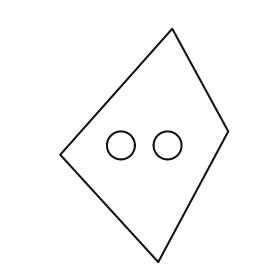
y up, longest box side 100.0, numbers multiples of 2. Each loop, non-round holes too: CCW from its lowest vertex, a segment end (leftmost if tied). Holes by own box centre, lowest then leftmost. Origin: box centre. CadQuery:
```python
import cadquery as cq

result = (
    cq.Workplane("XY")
    .moveTo(6.0, -50.0)
    .lineTo(36.0, 6.0)
    .lineTo(12.0, 50.0)
    .lineTo(-36.0, -4.0)
    .close()
    .moveTo(-10.0, 0.0)
    .circle(6.0)
    .moveTo(10.0, 0.0)
    .circle(6.0)
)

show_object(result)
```